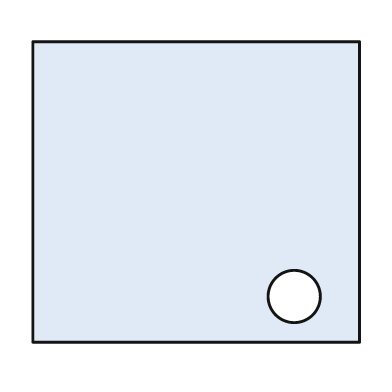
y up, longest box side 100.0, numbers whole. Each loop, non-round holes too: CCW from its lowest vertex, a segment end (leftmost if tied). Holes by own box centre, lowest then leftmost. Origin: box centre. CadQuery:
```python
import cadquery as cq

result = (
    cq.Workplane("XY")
    .moveTo(-50.0, -46.0)
    .lineTo(50.0, -46.0)
    .lineTo(50.0, 46.0)
    .lineTo(-50.0, 46.0)
    .close()
    .moveTo(30.0, -32.0)
    .circle(8.0)
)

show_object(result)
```